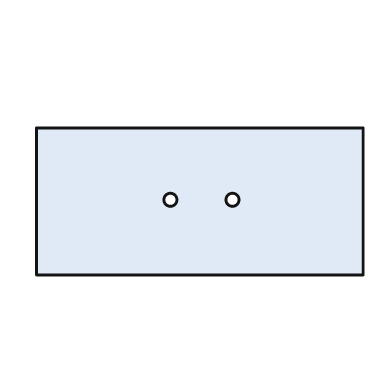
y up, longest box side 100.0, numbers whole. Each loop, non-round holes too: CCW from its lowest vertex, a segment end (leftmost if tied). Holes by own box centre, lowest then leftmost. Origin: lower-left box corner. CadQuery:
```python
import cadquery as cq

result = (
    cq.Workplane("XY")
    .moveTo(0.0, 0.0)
    .lineTo(100.0, 0.0)
    .lineTo(100.0, 45.0)
    .lineTo(0.0, 45.0)
    .close()
    .moveTo(41.0, 23.0)
    .circle(2.0)
    .moveTo(60.0, 23.0)
    .circle(2.0)
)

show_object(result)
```